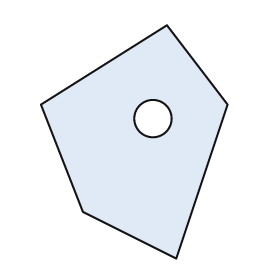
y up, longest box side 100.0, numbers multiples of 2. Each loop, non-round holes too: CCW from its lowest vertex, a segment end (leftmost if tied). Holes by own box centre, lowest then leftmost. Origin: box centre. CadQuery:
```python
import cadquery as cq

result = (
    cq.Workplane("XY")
    .moveTo(18.0, -50.0)
    .lineTo(40.0, 16.0)
    .lineTo(14.0, 50.0)
    .lineTo(-40.0, 16.0)
    .lineTo(-22.0, -30.0)
    .close()
    .moveTo(8.0, 10.0)
    .circle(8.0)
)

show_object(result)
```